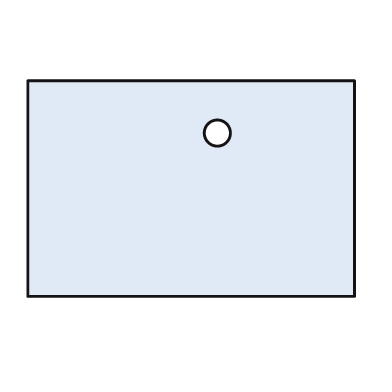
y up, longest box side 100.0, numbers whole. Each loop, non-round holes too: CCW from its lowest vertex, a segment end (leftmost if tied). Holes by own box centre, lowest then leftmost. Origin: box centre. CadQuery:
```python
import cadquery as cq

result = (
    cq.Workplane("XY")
    .moveTo(-50.0, -33.0)
    .lineTo(50.0, -33.0)
    .lineTo(50.0, 33.0)
    .lineTo(-50.0, 33.0)
    .close()
    .moveTo(8.0, 17.0)
    .circle(4.0)
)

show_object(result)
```